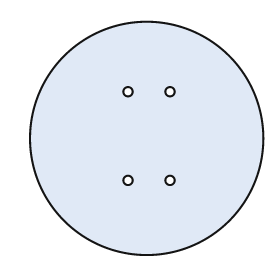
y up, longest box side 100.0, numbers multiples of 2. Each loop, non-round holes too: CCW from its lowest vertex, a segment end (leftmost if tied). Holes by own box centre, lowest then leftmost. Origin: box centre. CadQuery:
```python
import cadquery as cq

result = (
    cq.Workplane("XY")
    .moveTo(0.0, 0.0)
    .circle(50.0)
    .moveTo(-8.0, -18.0)
    .circle(2.0)
    .moveTo(10.0, -18.0)
    .circle(2.0)
    .moveTo(-8.0, 20.0)
    .circle(2.0)
    .moveTo(10.0, 20.0)
    .circle(2.0)
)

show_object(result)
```